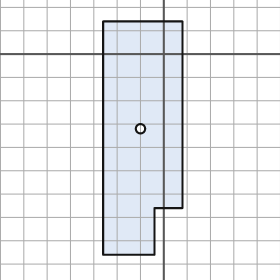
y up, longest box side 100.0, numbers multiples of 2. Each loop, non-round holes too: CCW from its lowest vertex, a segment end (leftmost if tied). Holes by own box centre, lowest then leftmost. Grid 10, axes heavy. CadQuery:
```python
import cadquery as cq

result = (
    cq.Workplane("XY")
    .moveTo(-26.0, -86.0)
    .lineTo(-4.0, -86.0)
    .lineTo(-4.0, -66.0)
    .lineTo(8.0, -66.0)
    .lineTo(8.0, 14.0)
    .lineTo(-26.0, 14.0)
    .close()
    .moveTo(-10.0, -32.0)
    .circle(2.0)
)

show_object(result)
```